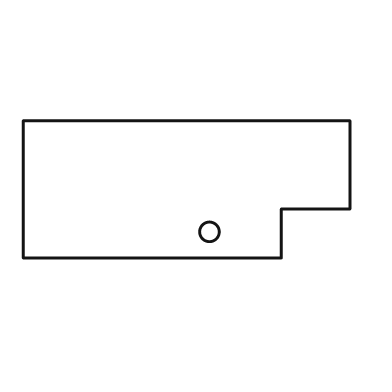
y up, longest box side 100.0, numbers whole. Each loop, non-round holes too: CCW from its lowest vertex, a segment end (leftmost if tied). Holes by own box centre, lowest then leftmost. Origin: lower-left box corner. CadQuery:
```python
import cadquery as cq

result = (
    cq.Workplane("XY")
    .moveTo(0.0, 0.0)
    .lineTo(79.0, 0.0)
    .lineTo(79.0, 15.0)
    .lineTo(100.0, 15.0)
    .lineTo(100.0, 42.0)
    .lineTo(0.0, 42.0)
    .close()
    .moveTo(57.0, 8.0)
    .circle(3.0)
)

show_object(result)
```